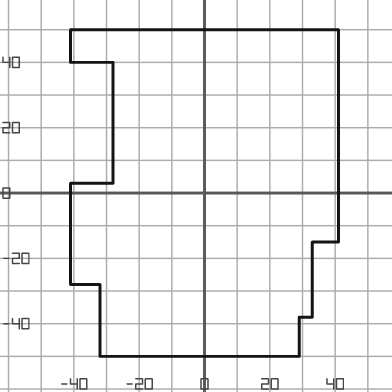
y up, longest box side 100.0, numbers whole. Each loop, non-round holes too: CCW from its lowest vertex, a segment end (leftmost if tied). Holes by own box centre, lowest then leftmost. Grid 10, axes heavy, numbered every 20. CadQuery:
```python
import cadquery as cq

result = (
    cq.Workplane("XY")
    .moveTo(-32.0, -50.0)
    .lineTo(29.0, -50.0)
    .lineTo(29.0, -38.0)
    .lineTo(33.0, -38.0)
    .lineTo(33.0, -15.0)
    .lineTo(41.0, -15.0)
    .lineTo(41.0, 50.0)
    .lineTo(-41.0, 50.0)
    .lineTo(-41.0, 40.0)
    .lineTo(-28.0, 40.0)
    .lineTo(-28.0, 3.0)
    .lineTo(-41.0, 3.0)
    .lineTo(-41.0, -28.0)
    .lineTo(-32.0, -28.0)
    .close()
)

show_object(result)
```